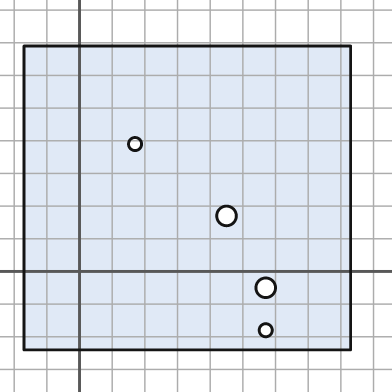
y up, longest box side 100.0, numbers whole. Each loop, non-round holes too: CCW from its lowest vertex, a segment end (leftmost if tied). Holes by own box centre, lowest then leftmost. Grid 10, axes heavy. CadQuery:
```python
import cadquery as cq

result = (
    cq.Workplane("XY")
    .moveTo(-17.0, -24.0)
    .lineTo(83.0, -24.0)
    .lineTo(83.0, 69.0)
    .lineTo(-17.0, 69.0)
    .close()
    .moveTo(57.0, -18.0)
    .circle(2.0)
    .moveTo(57.0, -5.0)
    .circle(3.0)
    .moveTo(45.0, 17.0)
    .circle(3.0)
    .moveTo(17.0, 39.0)
    .circle(2.0)
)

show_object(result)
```